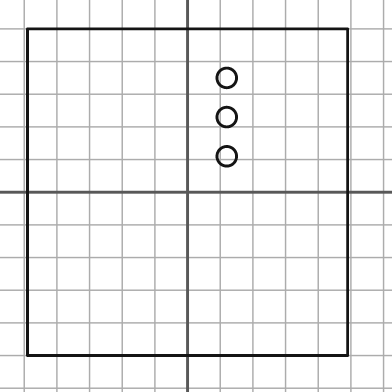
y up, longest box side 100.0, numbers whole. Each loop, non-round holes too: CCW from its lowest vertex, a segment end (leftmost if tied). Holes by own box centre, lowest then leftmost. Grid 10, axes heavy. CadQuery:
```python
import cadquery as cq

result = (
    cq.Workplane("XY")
    .moveTo(-49.0, -50.0)
    .lineTo(49.0, -50.0)
    .lineTo(49.0, 50.0)
    .lineTo(-49.0, 50.0)
    .close()
    .moveTo(12.0, 11.0)
    .circle(3.0)
    .moveTo(12.0, 23.0)
    .circle(3.0)
    .moveTo(12.0, 35.0)
    .circle(3.0)
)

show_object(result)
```